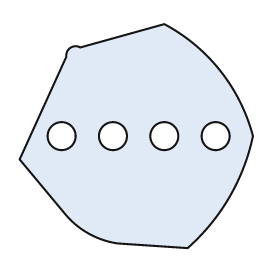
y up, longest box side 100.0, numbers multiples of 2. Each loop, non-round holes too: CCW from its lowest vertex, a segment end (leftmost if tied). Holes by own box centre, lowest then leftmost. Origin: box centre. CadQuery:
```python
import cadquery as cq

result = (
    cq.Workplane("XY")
    .moveTo(22.0, -48.0)
    .threePointArc((40.0, -26.0), (50.0, 0.0))
    .threePointArc((36.0, 28.0), (12.0, 48.0))
    .lineTo(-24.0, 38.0)
    .threePointArc((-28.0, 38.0), (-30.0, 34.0))
    .lineTo(-50.0, -10.0)
    .lineTo(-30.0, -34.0)
    .threePointArc((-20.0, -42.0), (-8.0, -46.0))
    .close()
    .moveTo(-32.0, 0.0)
    .circle(6.0)
    .moveTo(-10.0, 0.0)
    .circle(6.0)
    .moveTo(12.0, 0.0)
    .circle(6.0)
    .moveTo(34.0, 0.0)
    .circle(6.0)
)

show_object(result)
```